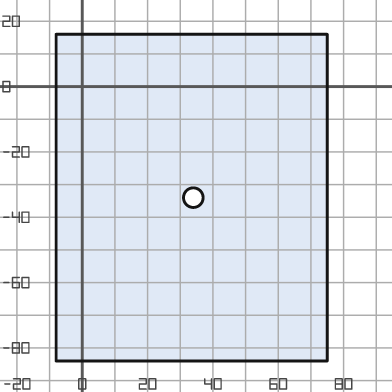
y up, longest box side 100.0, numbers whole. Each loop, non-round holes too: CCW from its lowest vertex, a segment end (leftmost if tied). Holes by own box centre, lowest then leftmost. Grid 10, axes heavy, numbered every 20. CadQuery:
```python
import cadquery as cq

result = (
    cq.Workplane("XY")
    .moveTo(-8.0, -84.0)
    .lineTo(75.0, -84.0)
    .lineTo(75.0, 16.0)
    .lineTo(-8.0, 16.0)
    .close()
    .moveTo(34.0, -34.0)
    .circle(3.0)
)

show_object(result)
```